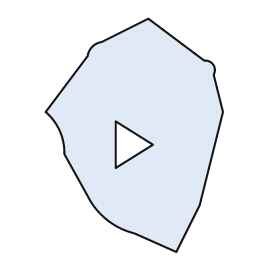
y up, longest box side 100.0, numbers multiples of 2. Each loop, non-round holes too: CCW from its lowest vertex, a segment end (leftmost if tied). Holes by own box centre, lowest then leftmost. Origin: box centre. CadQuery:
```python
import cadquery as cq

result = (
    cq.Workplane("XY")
    .moveTo(18.0, -50.0)
    .lineTo(28.0, -30.0)
    .lineTo(38.0, 10.0)
    .lineTo(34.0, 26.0)
    .threePointArc((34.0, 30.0), (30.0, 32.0))
    .lineTo(6.0, 50.0)
    .lineTo(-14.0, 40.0)
    .threePointArc((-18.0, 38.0), (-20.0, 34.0))
    .lineTo(-38.0, 10.0)
    .threePointArc((-32.0, 2.0), (-30.0, -8.0))
    .lineTo(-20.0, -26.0)
    .threePointArc((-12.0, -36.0), (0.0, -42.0))
    .close()
    .moveTo(-8.0, -14.0)
    .lineTo(8.0, -4.0)
    .lineTo(-8.0, 6.0)
    .close()
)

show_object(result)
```